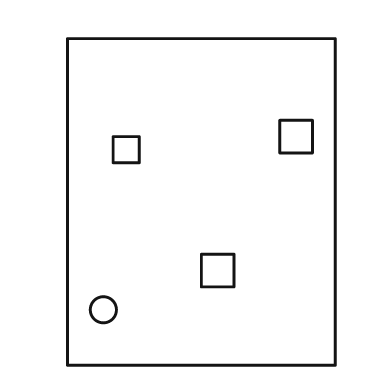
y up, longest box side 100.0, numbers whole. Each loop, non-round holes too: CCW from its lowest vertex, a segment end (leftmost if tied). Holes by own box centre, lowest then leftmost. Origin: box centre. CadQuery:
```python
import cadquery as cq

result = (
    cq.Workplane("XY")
    .moveTo(-41.0, -50.0)
    .lineTo(41.0, -50.0)
    .lineTo(41.0, 50.0)
    .lineTo(-41.0, 50.0)
    .close()
    .moveTo(-30.0, -33.0)
    .circle(4.0)
    .moveTo(0.0, -26.0)
    .lineTo(10.0, -26.0)
    .lineTo(10.0, -16.0)
    .lineTo(0.0, -16.0)
    .close()
    .moveTo(-27.0, 12.0)
    .lineTo(-19.0, 12.0)
    .lineTo(-19.0, 20.0)
    .lineTo(-27.0, 20.0)
    .close()
    .moveTo(24.0, 15.0)
    .lineTo(34.0, 15.0)
    .lineTo(34.0, 25.0)
    .lineTo(24.0, 25.0)
    .close()
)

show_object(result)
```